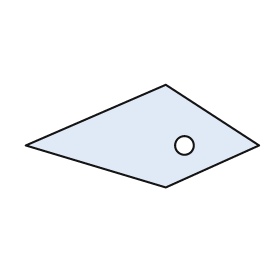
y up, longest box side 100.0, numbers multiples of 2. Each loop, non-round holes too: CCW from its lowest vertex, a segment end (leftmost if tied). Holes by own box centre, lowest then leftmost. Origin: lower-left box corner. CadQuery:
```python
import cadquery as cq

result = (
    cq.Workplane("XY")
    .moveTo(60.0, 0.0)
    .lineTo(100.0, 18.0)
    .lineTo(60.0, 44.0)
    .lineTo(0.0, 18.0)
    .close()
    .moveTo(68.0, 18.0)
    .circle(4.0)
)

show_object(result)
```